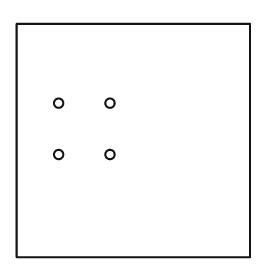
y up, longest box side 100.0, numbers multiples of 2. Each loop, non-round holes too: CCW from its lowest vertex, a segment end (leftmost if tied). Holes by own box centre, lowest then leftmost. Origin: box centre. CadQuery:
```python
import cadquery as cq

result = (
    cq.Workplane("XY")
    .moveTo(-50.0, -50.0)
    .lineTo(50.0, -50.0)
    .lineTo(50.0, 50.0)
    .lineTo(-50.0, 50.0)
    .close()
    .moveTo(-32.0, -6.0)
    .circle(2.0)
    .moveTo(-10.0, -6.0)
    .circle(2.0)
    .moveTo(-32.0, 16.0)
    .circle(2.0)
    .moveTo(-10.0, 16.0)
    .circle(2.0)
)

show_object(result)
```